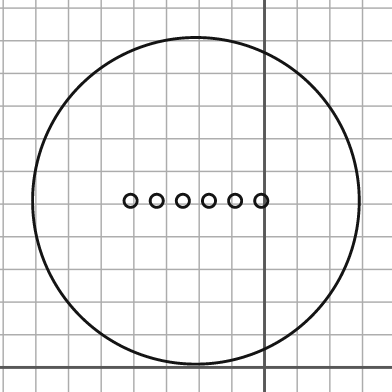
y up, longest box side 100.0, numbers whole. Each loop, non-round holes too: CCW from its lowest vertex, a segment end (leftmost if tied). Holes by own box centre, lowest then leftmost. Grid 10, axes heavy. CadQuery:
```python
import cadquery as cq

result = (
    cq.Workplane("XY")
    .moveTo(-21.0, 51.0)
    .circle(50.0)
    .moveTo(-41.0, 51.0)
    .circle(2.0)
    .moveTo(-33.0, 51.0)
    .circle(2.0)
    .moveTo(-25.0, 51.0)
    .circle(2.0)
    .moveTo(-17.0, 51.0)
    .circle(2.0)
    .moveTo(-9.0, 51.0)
    .circle(2.0)
    .moveTo(-1.0, 51.0)
    .circle(2.0)
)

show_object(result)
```